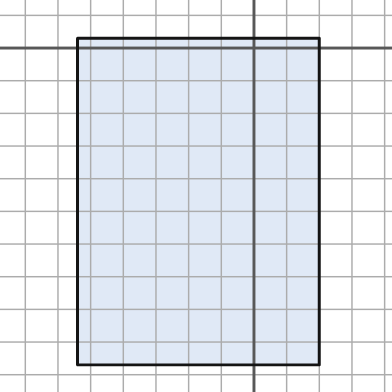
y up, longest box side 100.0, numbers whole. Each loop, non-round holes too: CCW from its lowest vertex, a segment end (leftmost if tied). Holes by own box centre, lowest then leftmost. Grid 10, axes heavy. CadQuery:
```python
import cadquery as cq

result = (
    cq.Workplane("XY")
    .moveTo(-54.0, -97.0)
    .lineTo(20.0, -97.0)
    .lineTo(20.0, 3.0)
    .lineTo(-54.0, 3.0)
    .close()
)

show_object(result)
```